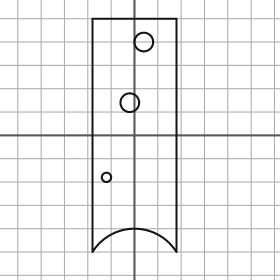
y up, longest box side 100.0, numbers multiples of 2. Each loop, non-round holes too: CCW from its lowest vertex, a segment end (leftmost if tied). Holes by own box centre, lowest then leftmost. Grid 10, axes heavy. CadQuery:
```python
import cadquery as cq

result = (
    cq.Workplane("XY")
    .moveTo(-18.0, -50.0)
    .threePointArc((0.0, -40.0), (18.0, -50.0))
    .lineTo(18.0, 50.0)
    .lineTo(-18.0, 50.0)
    .close()
    .moveTo(-12.0, -18.0)
    .circle(2.0)
    .moveTo(-2.0, 14.0)
    .circle(4.0)
    .moveTo(4.0, 40.0)
    .circle(4.0)
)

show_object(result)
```